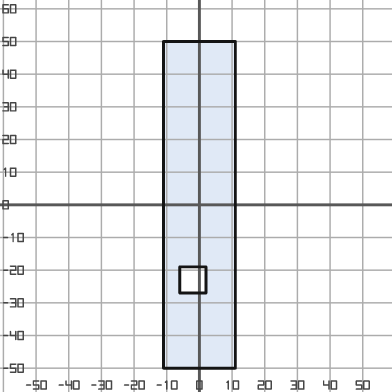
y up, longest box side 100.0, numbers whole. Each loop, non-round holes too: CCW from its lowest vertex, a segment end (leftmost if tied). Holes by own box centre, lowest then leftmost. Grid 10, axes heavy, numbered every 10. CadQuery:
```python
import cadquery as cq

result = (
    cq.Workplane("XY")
    .moveTo(-11.0, -50.0)
    .lineTo(11.0, -50.0)
    .lineTo(11.0, 50.0)
    .lineTo(-11.0, 50.0)
    .close()
    .moveTo(-6.0, -27.0)
    .lineTo(2.0, -27.0)
    .lineTo(2.0, -19.0)
    .lineTo(-6.0, -19.0)
    .close()
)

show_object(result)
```